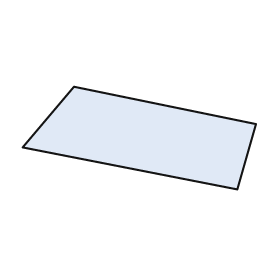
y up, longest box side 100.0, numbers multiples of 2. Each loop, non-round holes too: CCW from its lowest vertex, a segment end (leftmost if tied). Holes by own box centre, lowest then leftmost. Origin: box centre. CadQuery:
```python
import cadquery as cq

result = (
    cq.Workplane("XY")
    .moveTo(42.0, -22.0)
    .lineTo(50.0, 6.0)
    .lineTo(-28.0, 22.0)
    .lineTo(-50.0, -4.0)
    .close()
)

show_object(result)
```